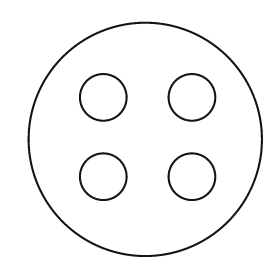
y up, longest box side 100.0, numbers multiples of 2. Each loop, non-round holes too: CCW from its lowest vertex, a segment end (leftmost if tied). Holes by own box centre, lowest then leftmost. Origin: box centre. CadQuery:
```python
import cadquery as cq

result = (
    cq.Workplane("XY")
    .moveTo(0.0, 0.0)
    .circle(50.0)
    .moveTo(-18.0, -16.0)
    .circle(10.0)
    .moveTo(20.0, -16.0)
    .circle(10.0)
    .moveTo(-18.0, 18.0)
    .circle(10.0)
    .moveTo(20.0, 18.0)
    .circle(10.0)
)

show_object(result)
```